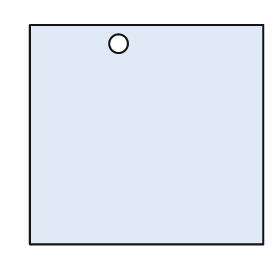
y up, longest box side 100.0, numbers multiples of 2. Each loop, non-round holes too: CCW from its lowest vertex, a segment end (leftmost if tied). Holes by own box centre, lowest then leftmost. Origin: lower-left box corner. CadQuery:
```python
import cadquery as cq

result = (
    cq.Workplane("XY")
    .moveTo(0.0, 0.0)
    .lineTo(100.0, 0.0)
    .lineTo(100.0, 94.0)
    .lineTo(0.0, 94.0)
    .close()
    .moveTo(38.0, 86.0)
    .circle(4.0)
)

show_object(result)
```